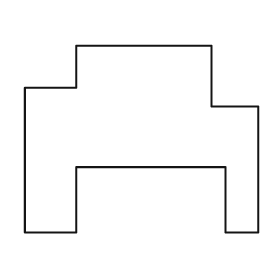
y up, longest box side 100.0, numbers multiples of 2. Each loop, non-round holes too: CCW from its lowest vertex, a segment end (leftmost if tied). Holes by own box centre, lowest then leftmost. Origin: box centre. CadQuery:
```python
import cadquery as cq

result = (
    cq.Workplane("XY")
    .moveTo(-50.0, -40.0)
    .lineTo(-28.0, -40.0)
    .lineTo(-28.0, -12.0)
    .lineTo(36.0, -12.0)
    .lineTo(36.0, -40.0)
    .lineTo(50.0, -40.0)
    .lineTo(50.0, 14.0)
    .lineTo(30.0, 14.0)
    .lineTo(30.0, 40.0)
    .lineTo(-28.0, 40.0)
    .lineTo(-28.0, 22.0)
    .lineTo(-50.0, 22.0)
    .close()
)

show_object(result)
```